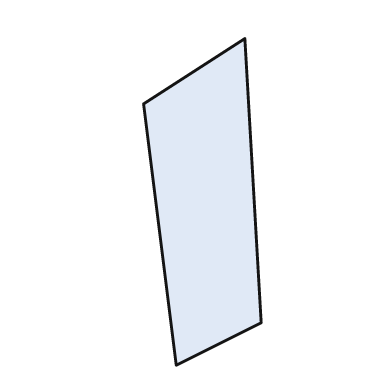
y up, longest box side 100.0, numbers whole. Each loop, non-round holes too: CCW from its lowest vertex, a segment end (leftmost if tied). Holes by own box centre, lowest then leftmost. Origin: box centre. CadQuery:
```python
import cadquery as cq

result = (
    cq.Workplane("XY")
    .moveTo(-8.0, -50.0)
    .lineTo(18.0, -37.0)
    .lineTo(13.0, 50.0)
    .lineTo(-18.0, 30.0)
    .close()
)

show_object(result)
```